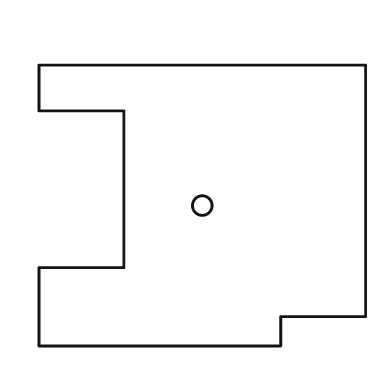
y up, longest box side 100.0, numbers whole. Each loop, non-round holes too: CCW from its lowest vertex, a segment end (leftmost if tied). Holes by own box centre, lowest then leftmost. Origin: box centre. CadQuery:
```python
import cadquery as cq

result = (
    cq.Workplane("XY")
    .moveTo(-50.0, -43.0)
    .lineTo(24.0, -43.0)
    .lineTo(24.0, -34.0)
    .lineTo(50.0, -34.0)
    .lineTo(50.0, 43.0)
    .lineTo(-50.0, 43.0)
    .lineTo(-50.0, 29.0)
    .lineTo(-24.0, 29.0)
    .lineTo(-24.0, -19.0)
    .lineTo(-50.0, -19.0)
    .close()
    .moveTo(0.0, 0.0)
    .circle(3.0)
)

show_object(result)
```